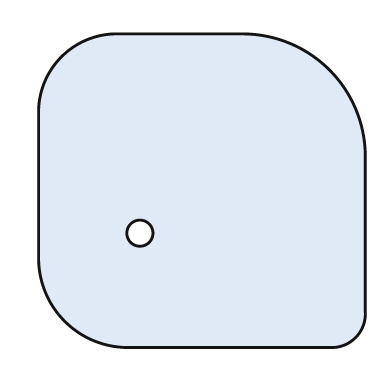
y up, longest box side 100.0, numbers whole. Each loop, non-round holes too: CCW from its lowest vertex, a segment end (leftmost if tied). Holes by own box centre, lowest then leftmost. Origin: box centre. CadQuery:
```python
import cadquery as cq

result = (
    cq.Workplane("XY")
    .moveTo(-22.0, -48.0)
    .lineTo(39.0, -48.0)
    .threePointArc((47.0, -45.0), (50.0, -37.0))
    .lineTo(50.0, 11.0)
    .threePointArc((39.0, 37.0), (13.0, 48.0))
    .lineTo(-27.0, 48.0)
    .threePointArc((-43.0, 41.0), (-50.0, 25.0))
    .lineTo(-50.0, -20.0)
    .threePointArc((-42.0, -40.0), (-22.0, -48.0))
    .close()
    .moveTo(-19.0, -13.0)
    .circle(4.0)
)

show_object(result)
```